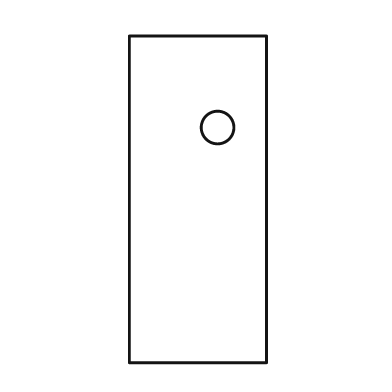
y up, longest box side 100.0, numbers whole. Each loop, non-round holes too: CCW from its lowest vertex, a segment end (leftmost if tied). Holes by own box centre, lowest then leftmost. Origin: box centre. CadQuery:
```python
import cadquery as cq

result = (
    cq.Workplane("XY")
    .moveTo(-21.0, -50.0)
    .lineTo(21.0, -50.0)
    .lineTo(21.0, 50.0)
    .lineTo(-21.0, 50.0)
    .close()
    .moveTo(6.0, 22.0)
    .circle(5.0)
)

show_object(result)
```